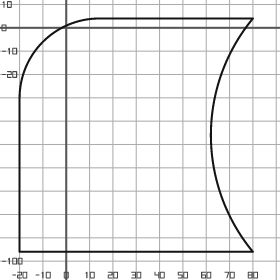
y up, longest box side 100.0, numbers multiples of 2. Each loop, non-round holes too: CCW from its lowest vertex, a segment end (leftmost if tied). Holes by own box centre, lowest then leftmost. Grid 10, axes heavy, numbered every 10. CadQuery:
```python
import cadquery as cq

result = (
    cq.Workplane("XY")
    .moveTo(-20.0, -96.0)
    .lineTo(80.0, -96.0)
    .threePointArc((62.0, -46.0), (80.0, 4.0))
    .lineTo(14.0, 4.0)
    .threePointArc((-10.0, -6.0), (-20.0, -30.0))
    .close()
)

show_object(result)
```